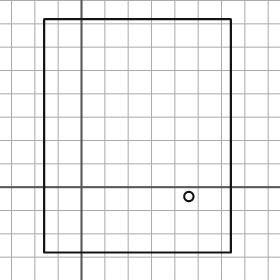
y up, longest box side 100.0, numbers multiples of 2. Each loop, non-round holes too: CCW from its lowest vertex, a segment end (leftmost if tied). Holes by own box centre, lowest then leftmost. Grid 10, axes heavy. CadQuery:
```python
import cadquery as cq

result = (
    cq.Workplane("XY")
    .moveTo(-16.0, -28.0)
    .lineTo(64.0, -28.0)
    .lineTo(64.0, 72.0)
    .lineTo(-16.0, 72.0)
    .close()
    .moveTo(46.0, -4.0)
    .circle(2.0)
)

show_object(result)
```